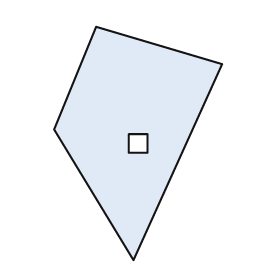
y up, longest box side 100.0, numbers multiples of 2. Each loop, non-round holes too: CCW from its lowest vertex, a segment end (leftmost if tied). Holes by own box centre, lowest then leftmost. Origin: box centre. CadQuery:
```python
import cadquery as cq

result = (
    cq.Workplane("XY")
    .moveTo(-2.0, -50.0)
    .lineTo(36.0, 34.0)
    .lineTo(-18.0, 50.0)
    .lineTo(-36.0, 6.0)
    .close()
    .moveTo(-4.0, -4.0)
    .lineTo(4.0, -4.0)
    .lineTo(4.0, 4.0)
    .lineTo(-4.0, 4.0)
    .close()
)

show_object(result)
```